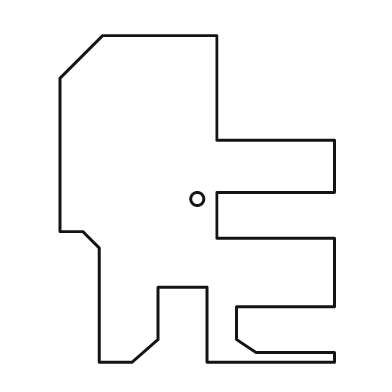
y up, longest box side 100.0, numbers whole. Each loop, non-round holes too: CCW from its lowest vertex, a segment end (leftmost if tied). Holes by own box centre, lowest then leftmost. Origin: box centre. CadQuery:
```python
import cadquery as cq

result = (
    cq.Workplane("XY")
    .moveTo(-30.0, -50.0)
    .lineTo(-20.0, -50.0)
    .lineTo(-12.0, -43.0)
    .lineTo(-12.0, -27.0)
    .lineTo(3.0, -27.0)
    .lineTo(3.0, -50.0)
    .lineTo(42.0, -50.0)
    .lineTo(42.0, -47.0)
    .lineTo(18.0, -47.0)
    .lineTo(12.0, -43.0)
    .lineTo(12.0, -33.0)
    .lineTo(42.0, -33.0)
    .lineTo(42.0, -12.0)
    .lineTo(6.0, -12.0)
    .lineTo(6.0, 2.0)
    .lineTo(42.0, 2.0)
    .lineTo(42.0, 18.0)
    .lineTo(6.0, 18.0)
    .lineTo(6.0, 50.0)
    .lineTo(-29.0, 50.0)
    .lineTo(-42.0, 37.0)
    .lineTo(-42.0, -10.0)
    .lineTo(-35.0, -10.0)
    .lineTo(-30.0, -15.0)
    .close()
    .moveTo(0.0, 0.0)
    .circle(2.0)
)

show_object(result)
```